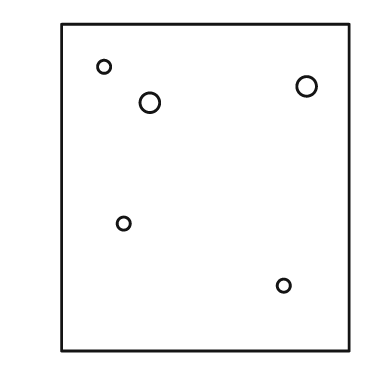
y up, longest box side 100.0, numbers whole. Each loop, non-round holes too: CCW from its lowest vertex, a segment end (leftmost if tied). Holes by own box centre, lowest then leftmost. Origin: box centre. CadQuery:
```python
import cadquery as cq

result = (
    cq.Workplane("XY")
    .moveTo(-44.0, -50.0)
    .lineTo(44.0, -50.0)
    .lineTo(44.0, 50.0)
    .lineTo(-44.0, 50.0)
    .close()
    .moveTo(24.0, -30.0)
    .circle(2.0)
    .moveTo(-25.0, -11.0)
    .circle(2.0)
    .moveTo(-17.0, 26.0)
    .circle(3.0)
    .moveTo(31.0, 31.0)
    .circle(3.0)
    .moveTo(-31.0, 37.0)
    .circle(2.0)
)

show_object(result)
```